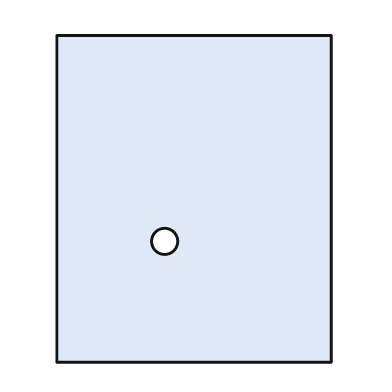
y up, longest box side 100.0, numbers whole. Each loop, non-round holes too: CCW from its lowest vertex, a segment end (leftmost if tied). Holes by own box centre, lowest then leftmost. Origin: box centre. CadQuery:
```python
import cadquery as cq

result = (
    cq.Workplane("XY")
    .moveTo(-42.0, -50.0)
    .lineTo(42.0, -50.0)
    .lineTo(42.0, 50.0)
    .lineTo(-42.0, 50.0)
    .close()
    .moveTo(-9.0, -13.0)
    .circle(4.0)
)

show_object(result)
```